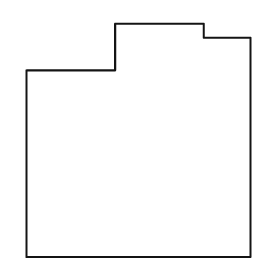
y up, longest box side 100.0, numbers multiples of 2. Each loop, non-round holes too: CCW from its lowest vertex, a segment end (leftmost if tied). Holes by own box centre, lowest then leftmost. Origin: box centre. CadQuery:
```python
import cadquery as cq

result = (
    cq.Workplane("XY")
    .moveTo(-48.0, -50.0)
    .lineTo(48.0, -50.0)
    .lineTo(48.0, 44.0)
    .lineTo(28.0, 44.0)
    .lineTo(28.0, 50.0)
    .lineTo(-10.0, 50.0)
    .lineTo(-10.0, 30.0)
    .lineTo(-48.0, 30.0)
    .close()
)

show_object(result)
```